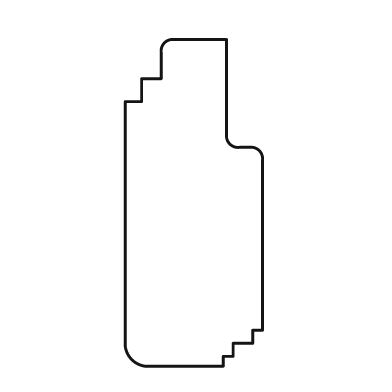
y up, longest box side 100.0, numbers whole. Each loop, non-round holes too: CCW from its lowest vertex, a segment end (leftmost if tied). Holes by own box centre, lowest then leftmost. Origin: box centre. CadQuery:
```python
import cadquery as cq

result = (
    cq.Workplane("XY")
    .moveTo(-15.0, -50.0)
    .lineTo(9.0, -50.0)
    .lineTo(9.0, -47.0)
    .lineTo(12.0, -47.0)
    .lineTo(12.0, -43.0)
    .lineTo(18.0, -43.0)
    .lineTo(18.0, -39.0)
    .lineTo(21.0, -39.0)
    .lineTo(21.0, 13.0)
    .threePointArc((20.0, 16.0), (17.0, 17.0))
    .lineTo(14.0, 17.0)
    .threePointArc((11.0, 18.0), (10.0, 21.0))
    .lineTo(10.0, 50.0)
    .lineTo(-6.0, 50.0)
    .threePointArc((-9.0, 49.0), (-10.0, 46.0))
    .lineTo(-10.0, 38.0)
    .lineTo(-16.0, 38.0)
    .lineTo(-16.0, 31.0)
    .lineTo(-21.0, 31.0)
    .lineTo(-21.0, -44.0)
    .threePointArc((-19.0, -48.0), (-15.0, -50.0))
    .close()
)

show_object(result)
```